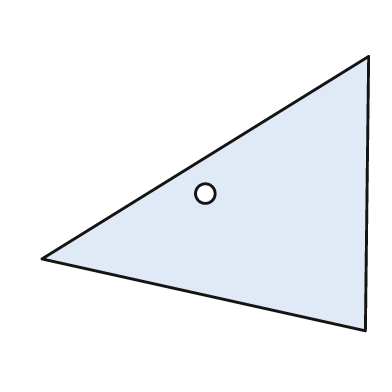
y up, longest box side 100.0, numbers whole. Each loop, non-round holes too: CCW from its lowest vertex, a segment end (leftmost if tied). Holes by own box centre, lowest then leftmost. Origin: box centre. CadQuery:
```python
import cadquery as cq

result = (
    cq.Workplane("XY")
    .moveTo(49.0, -42.0)
    .lineTo(50.0, 42.0)
    .lineTo(-50.0, -20.0)
    .close()
    .moveTo(0.0, 0.0)
    .circle(3.0)
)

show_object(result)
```